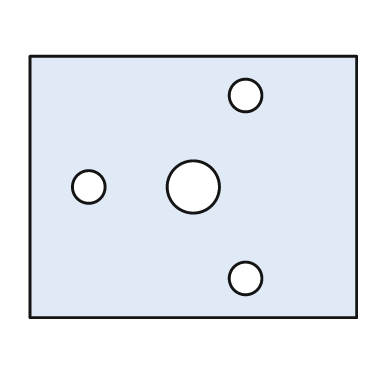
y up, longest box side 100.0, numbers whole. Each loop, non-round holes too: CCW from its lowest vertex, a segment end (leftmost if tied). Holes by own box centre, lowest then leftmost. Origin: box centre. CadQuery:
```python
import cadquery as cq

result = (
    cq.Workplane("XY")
    .moveTo(-50.0, -40.0)
    .lineTo(50.0, -40.0)
    .lineTo(50.0, 40.0)
    .lineTo(-50.0, 40.0)
    .close()
    .moveTo(16.0, -28.0)
    .circle(5.0)
    .moveTo(-32.0, 0.0)
    .circle(5.0)
    .moveTo(0.0, 0.0)
    .circle(8.0)
    .moveTo(16.0, 28.0)
    .circle(5.0)
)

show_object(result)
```